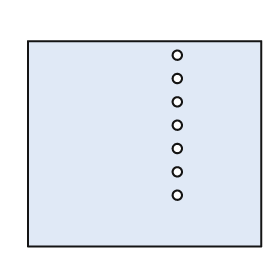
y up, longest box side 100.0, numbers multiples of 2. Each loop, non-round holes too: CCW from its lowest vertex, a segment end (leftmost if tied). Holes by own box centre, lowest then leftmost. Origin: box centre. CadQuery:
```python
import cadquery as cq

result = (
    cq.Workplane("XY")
    .moveTo(-50.0, -44.0)
    .lineTo(50.0, -44.0)
    .lineTo(50.0, 44.0)
    .lineTo(-50.0, 44.0)
    .close()
    .moveTo(14.0, -22.0)
    .circle(2.0)
    .moveTo(14.0, -12.0)
    .circle(2.0)
    .moveTo(14.0, -2.0)
    .circle(2.0)
    .moveTo(14.0, 8.0)
    .circle(2.0)
    .moveTo(14.0, 18.0)
    .circle(2.0)
    .moveTo(14.0, 28.0)
    .circle(2.0)
    .moveTo(14.0, 38.0)
    .circle(2.0)
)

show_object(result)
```